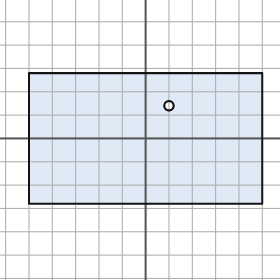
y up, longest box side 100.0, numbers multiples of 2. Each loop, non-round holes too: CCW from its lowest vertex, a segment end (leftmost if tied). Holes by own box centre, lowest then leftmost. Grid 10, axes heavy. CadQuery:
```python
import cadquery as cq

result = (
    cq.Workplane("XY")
    .moveTo(-50.0, -28.0)
    .lineTo(50.0, -28.0)
    .lineTo(50.0, 28.0)
    .lineTo(-50.0, 28.0)
    .close()
    .moveTo(10.0, 14.0)
    .circle(2.0)
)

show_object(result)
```